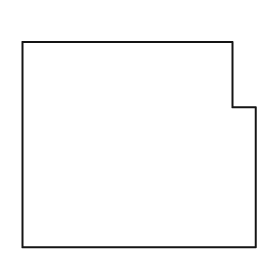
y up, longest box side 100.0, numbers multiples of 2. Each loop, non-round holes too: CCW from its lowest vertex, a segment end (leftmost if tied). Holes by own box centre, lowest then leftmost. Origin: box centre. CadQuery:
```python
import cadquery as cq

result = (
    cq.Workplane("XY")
    .moveTo(-50.0, -44.0)
    .lineTo(50.0, -44.0)
    .lineTo(50.0, 16.0)
    .lineTo(40.0, 16.0)
    .lineTo(40.0, 44.0)
    .lineTo(-50.0, 44.0)
    .close()
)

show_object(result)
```